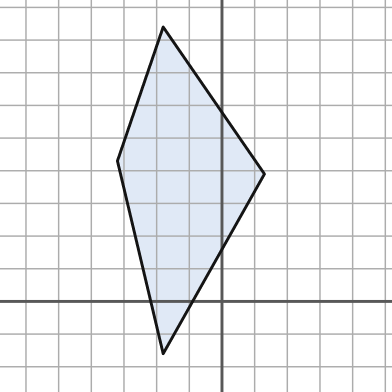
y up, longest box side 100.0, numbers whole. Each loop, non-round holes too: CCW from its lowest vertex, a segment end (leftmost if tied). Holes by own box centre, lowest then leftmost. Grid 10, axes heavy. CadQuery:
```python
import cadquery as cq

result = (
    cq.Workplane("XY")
    .moveTo(-18.0, -16.0)
    .lineTo(13.0, 39.0)
    .lineTo(-18.0, 84.0)
    .lineTo(-32.0, 43.0)
    .close()
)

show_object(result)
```